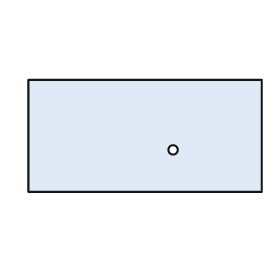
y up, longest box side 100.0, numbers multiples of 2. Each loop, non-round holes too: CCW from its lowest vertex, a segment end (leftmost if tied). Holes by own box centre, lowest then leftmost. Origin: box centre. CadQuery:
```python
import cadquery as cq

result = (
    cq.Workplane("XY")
    .moveTo(-50.0, -24.0)
    .lineTo(50.0, -24.0)
    .lineTo(50.0, 24.0)
    .lineTo(-50.0, 24.0)
    .close()
    .moveTo(12.0, -6.0)
    .circle(2.0)
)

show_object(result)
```